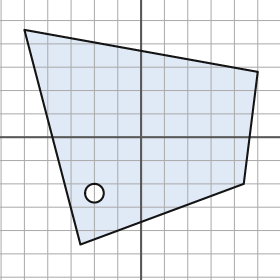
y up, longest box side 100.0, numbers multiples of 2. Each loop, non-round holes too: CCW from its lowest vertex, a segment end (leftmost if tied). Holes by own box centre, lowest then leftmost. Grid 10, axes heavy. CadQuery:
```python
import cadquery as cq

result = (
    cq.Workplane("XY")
    .moveTo(-26.0, -46.0)
    .lineTo(44.0, -20.0)
    .lineTo(50.0, 28.0)
    .lineTo(-50.0, 46.0)
    .close()
    .moveTo(-20.0, -24.0)
    .circle(4.0)
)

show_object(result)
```